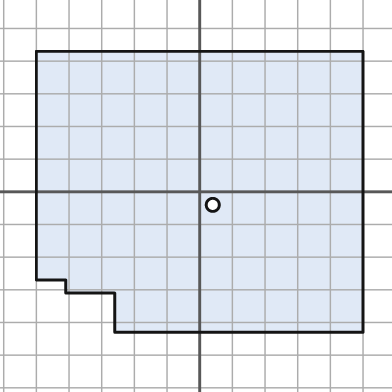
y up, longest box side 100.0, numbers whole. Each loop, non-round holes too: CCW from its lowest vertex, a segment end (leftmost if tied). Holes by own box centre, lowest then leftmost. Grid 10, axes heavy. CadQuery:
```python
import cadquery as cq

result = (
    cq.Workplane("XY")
    .moveTo(-26.0, -43.0)
    .lineTo(50.0, -43.0)
    .lineTo(50.0, 43.0)
    .lineTo(-50.0, 43.0)
    .lineTo(-50.0, -27.0)
    .lineTo(-41.0, -27.0)
    .lineTo(-41.0, -31.0)
    .lineTo(-26.0, -31.0)
    .close()
    .moveTo(4.0, -4.0)
    .circle(2.0)
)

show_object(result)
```